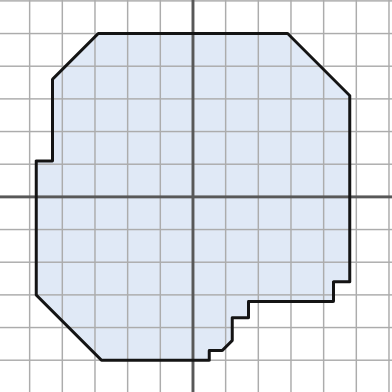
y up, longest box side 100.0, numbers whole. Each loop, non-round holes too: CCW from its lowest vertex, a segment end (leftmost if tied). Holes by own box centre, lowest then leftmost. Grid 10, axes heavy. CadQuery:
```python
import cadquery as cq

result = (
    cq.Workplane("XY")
    .moveTo(-28.0, -50.0)
    .lineTo(5.0, -50.0)
    .lineTo(5.0, -47.0)
    .lineTo(9.0, -47.0)
    .lineTo(12.0, -44.0)
    .lineTo(12.0, -37.0)
    .lineTo(17.0, -37.0)
    .lineTo(17.0, -32.0)
    .lineTo(43.0, -32.0)
    .lineTo(43.0, -26.0)
    .lineTo(48.0, -26.0)
    .lineTo(48.0, 31.0)
    .lineTo(29.0, 50.0)
    .lineTo(-29.0, 50.0)
    .lineTo(-43.0, 36.0)
    .lineTo(-43.0, 11.0)
    .lineTo(-48.0, 11.0)
    .lineTo(-48.0, -30.0)
    .close()
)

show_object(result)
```